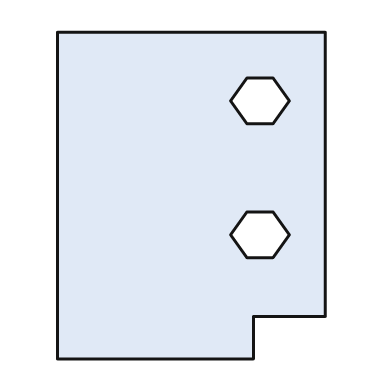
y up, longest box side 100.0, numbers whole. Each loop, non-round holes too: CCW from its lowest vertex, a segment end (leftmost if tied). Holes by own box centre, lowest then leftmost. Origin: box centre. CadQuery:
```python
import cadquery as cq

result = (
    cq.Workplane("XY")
    .moveTo(-41.0, -50.0)
    .lineTo(19.0, -50.0)
    .lineTo(19.0, -37.0)
    .lineTo(41.0, -37.0)
    .lineTo(41.0, 50.0)
    .lineTo(-41.0, 50.0)
    .close()
    .moveTo(17.0, -19.0)
    .lineTo(25.0, -19.0)
    .lineTo(30.0, -12.0)
    .lineTo(25.0, -5.0)
    .lineTo(17.0, -5.0)
    .lineTo(12.0, -12.0)
    .close()
    .moveTo(17.0, 22.0)
    .lineTo(25.0, 22.0)
    .lineTo(30.0, 29.0)
    .lineTo(25.0, 36.0)
    .lineTo(17.0, 36.0)
    .lineTo(12.0, 29.0)
    .close()
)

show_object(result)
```